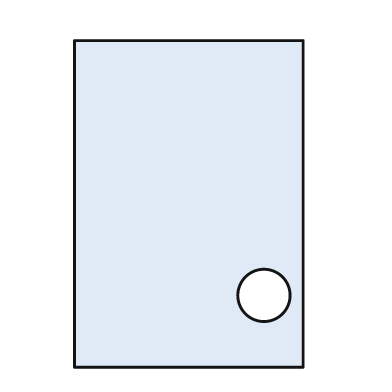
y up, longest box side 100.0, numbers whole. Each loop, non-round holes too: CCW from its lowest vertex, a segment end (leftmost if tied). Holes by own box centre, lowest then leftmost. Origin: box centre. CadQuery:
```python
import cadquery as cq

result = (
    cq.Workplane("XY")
    .moveTo(-35.0, -50.0)
    .lineTo(35.0, -50.0)
    .lineTo(35.0, 50.0)
    .lineTo(-35.0, 50.0)
    .close()
    .moveTo(23.0, -28.0)
    .circle(8.0)
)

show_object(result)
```